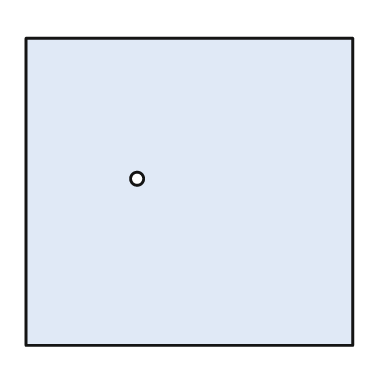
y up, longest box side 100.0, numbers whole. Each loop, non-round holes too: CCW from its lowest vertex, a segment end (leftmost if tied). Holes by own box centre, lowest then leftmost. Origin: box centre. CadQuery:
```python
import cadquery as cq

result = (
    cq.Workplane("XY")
    .moveTo(-50.0, -47.0)
    .lineTo(50.0, -47.0)
    .lineTo(50.0, 47.0)
    .lineTo(-50.0, 47.0)
    .close()
    .moveTo(-16.0, 4.0)
    .circle(2.0)
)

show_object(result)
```